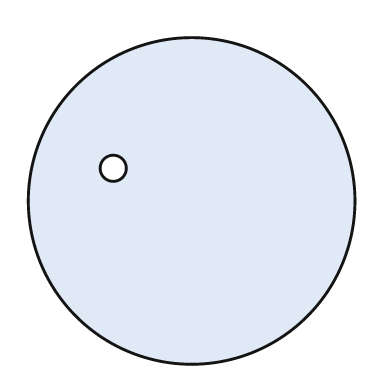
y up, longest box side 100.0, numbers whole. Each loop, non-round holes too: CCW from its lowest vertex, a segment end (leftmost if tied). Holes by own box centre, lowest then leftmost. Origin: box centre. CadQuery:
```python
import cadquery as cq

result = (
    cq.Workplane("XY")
    .moveTo(0.0, 0.0)
    .circle(50.0)
    .moveTo(-24.0, 10.0)
    .circle(4.0)
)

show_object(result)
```